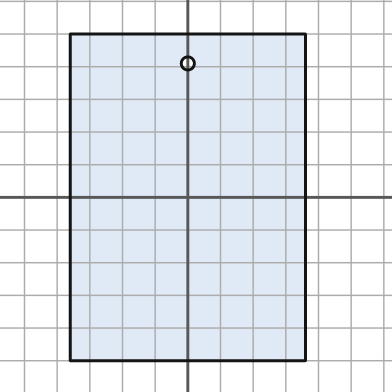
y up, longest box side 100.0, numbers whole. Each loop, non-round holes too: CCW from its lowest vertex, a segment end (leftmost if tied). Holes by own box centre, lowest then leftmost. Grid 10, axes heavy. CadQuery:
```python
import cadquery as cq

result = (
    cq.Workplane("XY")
    .moveTo(-36.0, -50.0)
    .lineTo(36.0, -50.0)
    .lineTo(36.0, 50.0)
    .lineTo(-36.0, 50.0)
    .close()
    .moveTo(0.0, 41.0)
    .circle(2.0)
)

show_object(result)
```